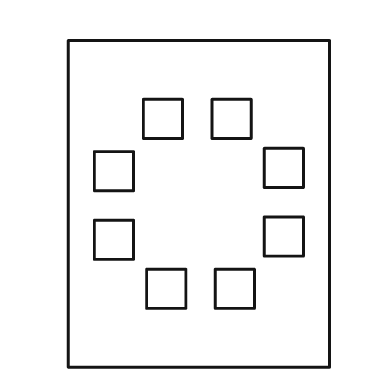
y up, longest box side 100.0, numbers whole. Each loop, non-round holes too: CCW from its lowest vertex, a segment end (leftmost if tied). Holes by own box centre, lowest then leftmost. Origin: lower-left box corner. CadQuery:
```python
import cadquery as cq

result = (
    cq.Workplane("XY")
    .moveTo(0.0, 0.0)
    .lineTo(80.0, 0.0)
    .lineTo(80.0, 100.0)
    .lineTo(0.0, 100.0)
    .close()
    .moveTo(24.0, 18.0)
    .lineTo(36.0, 18.0)
    .lineTo(36.0, 30.0)
    .lineTo(24.0, 30.0)
    .close()
    .moveTo(45.0, 18.0)
    .lineTo(57.0, 18.0)
    .lineTo(57.0, 30.0)
    .lineTo(45.0, 30.0)
    .close()
    .moveTo(8.0, 33.0)
    .lineTo(20.0, 33.0)
    .lineTo(20.0, 45.0)
    .lineTo(8.0, 45.0)
    .close()
    .moveTo(60.0, 34.0)
    .lineTo(72.0, 34.0)
    .lineTo(72.0, 46.0)
    .lineTo(60.0, 46.0)
    .close()
    .moveTo(8.0, 54.0)
    .lineTo(20.0, 54.0)
    .lineTo(20.0, 66.0)
    .lineTo(8.0, 66.0)
    .close()
    .moveTo(60.0, 55.0)
    .lineTo(72.0, 55.0)
    .lineTo(72.0, 67.0)
    .lineTo(60.0, 67.0)
    .close()
    .moveTo(23.0, 70.0)
    .lineTo(35.0, 70.0)
    .lineTo(35.0, 82.0)
    .lineTo(23.0, 82.0)
    .close()
    .moveTo(44.0, 70.0)
    .lineTo(56.0, 70.0)
    .lineTo(56.0, 82.0)
    .lineTo(44.0, 82.0)
    .close()
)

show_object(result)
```